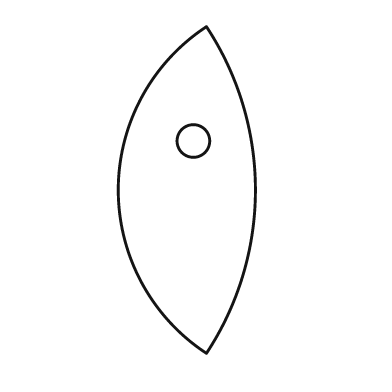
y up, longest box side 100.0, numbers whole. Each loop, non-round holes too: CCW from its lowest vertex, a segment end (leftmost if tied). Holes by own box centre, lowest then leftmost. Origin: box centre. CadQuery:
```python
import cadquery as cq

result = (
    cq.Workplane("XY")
    .moveTo(6.0, -50.0)
    .threePointArc((21.0, 0.0), (6.0, 50.0))
    .threePointArc((-21.0, 0.0), (6.0, -50.0))
    .close()
    .moveTo(2.0, 15.0)
    .circle(5.0)
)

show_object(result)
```